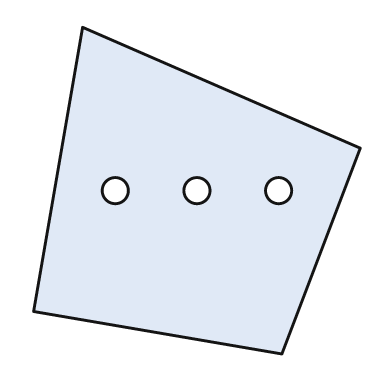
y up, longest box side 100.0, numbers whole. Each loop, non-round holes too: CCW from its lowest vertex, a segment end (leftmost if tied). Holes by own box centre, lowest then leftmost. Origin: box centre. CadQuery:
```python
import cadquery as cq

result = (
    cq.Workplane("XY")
    .moveTo(26.0, -50.0)
    .lineTo(50.0, 13.0)
    .lineTo(-35.0, 50.0)
    .lineTo(-50.0, -37.0)
    .close()
    .moveTo(-25.0, 0.0)
    .circle(4.0)
    .moveTo(0.0, 0.0)
    .circle(4.0)
    .moveTo(25.0, 0.0)
    .circle(4.0)
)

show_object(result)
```